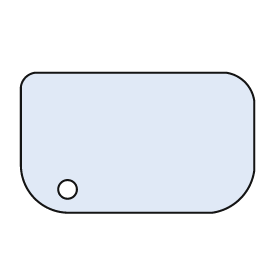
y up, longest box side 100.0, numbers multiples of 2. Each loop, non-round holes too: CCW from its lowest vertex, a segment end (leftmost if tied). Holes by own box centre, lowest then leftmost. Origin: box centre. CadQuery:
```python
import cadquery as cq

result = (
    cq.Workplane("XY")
    .moveTo(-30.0, -30.0)
    .lineTo(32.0, -30.0)
    .threePointArc((44.0, -24.0), (50.0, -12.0))
    .lineTo(50.0, 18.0)
    .threePointArc((46.0, 26.0), (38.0, 30.0))
    .lineTo(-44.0, 30.0)
    .threePointArc((-48.0, 28.0), (-50.0, 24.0))
    .lineTo(-50.0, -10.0)
    .threePointArc((-44.0, -24.0), (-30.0, -30.0))
    .close()
    .moveTo(-30.0, -20.0)
    .circle(4.0)
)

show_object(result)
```